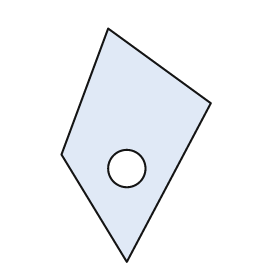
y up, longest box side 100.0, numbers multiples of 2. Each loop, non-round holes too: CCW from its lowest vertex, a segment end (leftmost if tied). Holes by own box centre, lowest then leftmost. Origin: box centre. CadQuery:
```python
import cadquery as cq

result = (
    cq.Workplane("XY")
    .moveTo(-4.0, -50.0)
    .lineTo(32.0, 18.0)
    .lineTo(-12.0, 50.0)
    .lineTo(-32.0, -4.0)
    .close()
    .moveTo(-4.0, -10.0)
    .circle(8.0)
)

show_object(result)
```